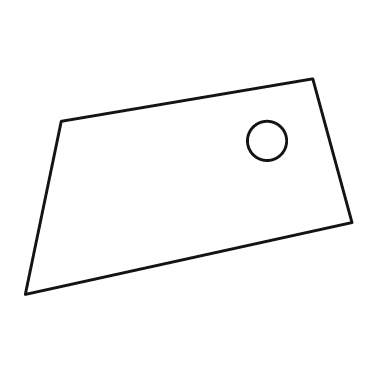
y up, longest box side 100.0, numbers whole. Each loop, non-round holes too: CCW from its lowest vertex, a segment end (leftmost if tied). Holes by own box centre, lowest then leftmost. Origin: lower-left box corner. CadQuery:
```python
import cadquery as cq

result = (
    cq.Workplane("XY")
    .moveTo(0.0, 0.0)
    .lineTo(100.0, 22.0)
    .lineTo(88.0, 66.0)
    .lineTo(11.0, 53.0)
    .close()
    .moveTo(74.0, 47.0)
    .circle(6.0)
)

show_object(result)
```